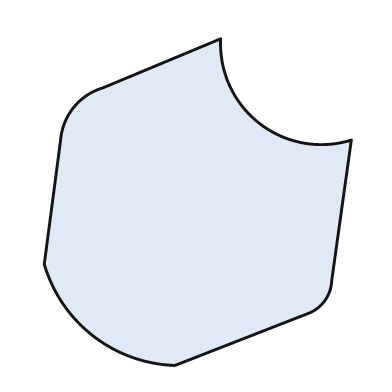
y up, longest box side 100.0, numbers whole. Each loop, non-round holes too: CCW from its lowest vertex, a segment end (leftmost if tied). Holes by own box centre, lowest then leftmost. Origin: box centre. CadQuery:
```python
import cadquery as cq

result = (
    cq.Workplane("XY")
    .moveTo(-7.0, -50.0)
    .lineTo(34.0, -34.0)
    .threePointArc((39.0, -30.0), (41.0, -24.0))
    .lineTo(47.0, 19.0)
    .threePointArc((19.0, 24.0), (7.0, 50.0))
    .lineTo(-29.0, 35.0)
    .threePointArc((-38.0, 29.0), (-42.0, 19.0))
    .lineTo(-47.0, -19.0)
    .threePointArc((-32.0, -41.0), (-7.0, -50.0))
    .close()
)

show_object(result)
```